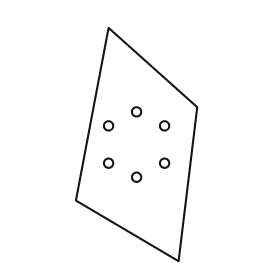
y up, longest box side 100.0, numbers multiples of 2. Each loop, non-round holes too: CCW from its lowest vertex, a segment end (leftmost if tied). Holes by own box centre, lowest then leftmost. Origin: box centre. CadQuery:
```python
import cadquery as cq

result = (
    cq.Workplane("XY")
    .moveTo(18.0, -50.0)
    .lineTo(26.0, 16.0)
    .lineTo(-12.0, 50.0)
    .lineTo(-26.0, -24.0)
    .close()
    .moveTo(0.0, -14.0)
    .circle(2.0)
    .moveTo(-12.0, -8.0)
    .circle(2.0)
    .moveTo(12.0, -8.0)
    .circle(2.0)
    .moveTo(-12.0, 8.0)
    .circle(2.0)
    .moveTo(12.0, 8.0)
    .circle(2.0)
    .moveTo(0.0, 14.0)
    .circle(2.0)
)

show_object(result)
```